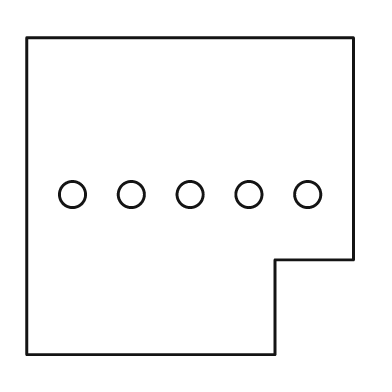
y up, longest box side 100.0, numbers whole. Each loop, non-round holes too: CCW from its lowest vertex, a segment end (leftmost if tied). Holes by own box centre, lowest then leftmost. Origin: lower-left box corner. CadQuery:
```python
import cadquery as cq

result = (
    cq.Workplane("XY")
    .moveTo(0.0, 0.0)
    .lineTo(76.0, 0.0)
    .lineTo(76.0, 29.0)
    .lineTo(100.0, 29.0)
    .lineTo(100.0, 97.0)
    .lineTo(0.0, 97.0)
    .close()
    .moveTo(14.0, 49.0)
    .circle(4.0)
    .moveTo(32.0, 49.0)
    .circle(4.0)
    .moveTo(50.0, 49.0)
    .circle(4.0)
    .moveTo(68.0, 49.0)
    .circle(4.0)
    .moveTo(86.0, 49.0)
    .circle(4.0)
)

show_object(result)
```